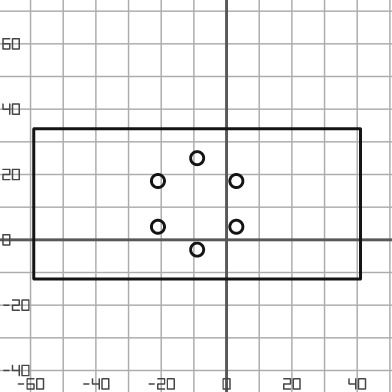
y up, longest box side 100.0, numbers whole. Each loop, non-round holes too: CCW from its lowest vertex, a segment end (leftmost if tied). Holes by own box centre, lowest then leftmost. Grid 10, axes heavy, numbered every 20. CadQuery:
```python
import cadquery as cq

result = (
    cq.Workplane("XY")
    .moveTo(-59.0, -12.0)
    .lineTo(41.0, -12.0)
    .lineTo(41.0, 34.0)
    .lineTo(-59.0, 34.0)
    .close()
    .moveTo(-9.0, -3.0)
    .circle(2.0)
    .moveTo(-21.0, 4.0)
    .circle(2.0)
    .moveTo(3.0, 4.0)
    .circle(2.0)
    .moveTo(-21.0, 18.0)
    .circle(2.0)
    .moveTo(3.0, 18.0)
    .circle(2.0)
    .moveTo(-9.0, 25.0)
    .circle(2.0)
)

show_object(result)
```